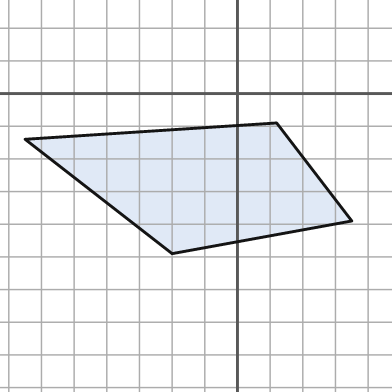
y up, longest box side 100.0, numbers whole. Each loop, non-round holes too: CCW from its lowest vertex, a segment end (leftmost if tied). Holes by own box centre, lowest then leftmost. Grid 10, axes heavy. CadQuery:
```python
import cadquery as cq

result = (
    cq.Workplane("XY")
    .moveTo(-20.0, -49.0)
    .lineTo(35.0, -39.0)
    .lineTo(12.0, -9.0)
    .lineTo(-65.0, -14.0)
    .close()
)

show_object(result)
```